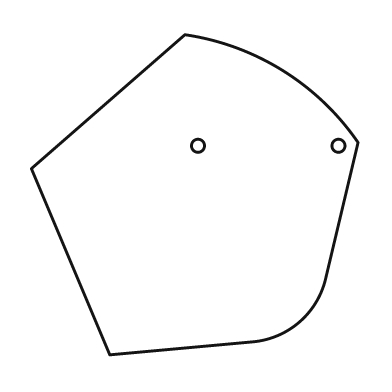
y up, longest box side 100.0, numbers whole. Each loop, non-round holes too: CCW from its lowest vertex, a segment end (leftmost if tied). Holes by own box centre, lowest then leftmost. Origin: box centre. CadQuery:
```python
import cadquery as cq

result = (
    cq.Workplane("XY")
    .moveTo(-26.0, -49.0)
    .lineTo(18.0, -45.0)
    .threePointArc((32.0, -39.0), (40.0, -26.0))
    .lineTo(50.0, 16.0)
    .threePointArc((27.0, 38.0), (-3.0, 49.0))
    .lineTo(-50.0, 8.0)
    .close()
    .moveTo(1.0, 15.0)
    .circle(2.0)
    .moveTo(44.0, 15.0)
    .circle(2.0)
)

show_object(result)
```